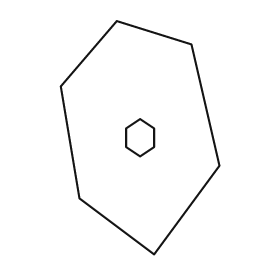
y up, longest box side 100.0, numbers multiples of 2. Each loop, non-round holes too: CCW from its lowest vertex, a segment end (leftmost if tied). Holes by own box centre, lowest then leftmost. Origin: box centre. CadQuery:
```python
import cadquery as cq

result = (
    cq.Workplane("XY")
    .moveTo(6.0, -50.0)
    .lineTo(34.0, -12.0)
    .lineTo(22.0, 40.0)
    .lineTo(-10.0, 50.0)
    .lineTo(-34.0, 22.0)
    .lineTo(-26.0, -26.0)
    .close()
    .moveTo(0.0, -8.0)
    .lineTo(6.0, -4.0)
    .lineTo(6.0, 4.0)
    .lineTo(0.0, 8.0)
    .lineTo(-6.0, 4.0)
    .lineTo(-6.0, -4.0)
    .close()
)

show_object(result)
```